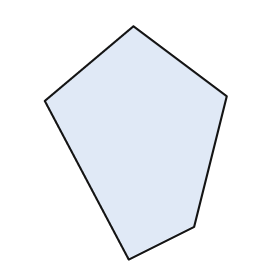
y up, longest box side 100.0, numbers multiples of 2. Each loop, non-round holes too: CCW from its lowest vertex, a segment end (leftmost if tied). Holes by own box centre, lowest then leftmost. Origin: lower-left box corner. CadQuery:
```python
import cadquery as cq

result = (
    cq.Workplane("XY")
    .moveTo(36.0, 0.0)
    .lineTo(64.0, 14.0)
    .lineTo(78.0, 70.0)
    .lineTo(38.0, 100.0)
    .lineTo(0.0, 68.0)
    .close()
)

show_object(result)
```